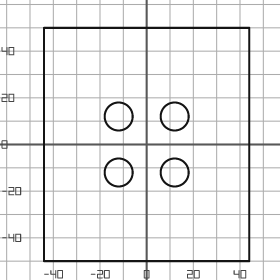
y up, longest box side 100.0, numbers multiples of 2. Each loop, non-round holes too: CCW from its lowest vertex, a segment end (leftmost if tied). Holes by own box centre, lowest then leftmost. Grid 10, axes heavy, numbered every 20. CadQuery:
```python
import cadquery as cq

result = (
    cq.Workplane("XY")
    .moveTo(-44.0, -50.0)
    .lineTo(44.0, -50.0)
    .lineTo(44.0, 50.0)
    .lineTo(-44.0, 50.0)
    .close()
    .moveTo(-12.0, -12.0)
    .circle(6.0)
    .moveTo(12.0, -12.0)
    .circle(6.0)
    .moveTo(-12.0, 12.0)
    .circle(6.0)
    .moveTo(12.0, 12.0)
    .circle(6.0)
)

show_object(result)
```